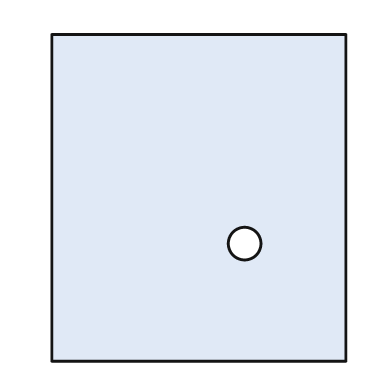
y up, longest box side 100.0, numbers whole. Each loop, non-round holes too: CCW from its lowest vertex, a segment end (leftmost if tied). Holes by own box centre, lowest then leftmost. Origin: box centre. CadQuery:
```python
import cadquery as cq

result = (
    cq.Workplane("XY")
    .moveTo(-45.0, -50.0)
    .lineTo(45.0, -50.0)
    .lineTo(45.0, 50.0)
    .lineTo(-45.0, 50.0)
    .close()
    .moveTo(14.0, -14.0)
    .circle(5.0)
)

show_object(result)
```